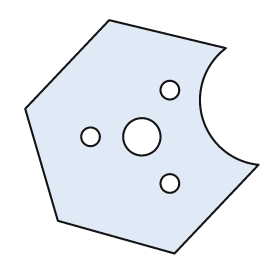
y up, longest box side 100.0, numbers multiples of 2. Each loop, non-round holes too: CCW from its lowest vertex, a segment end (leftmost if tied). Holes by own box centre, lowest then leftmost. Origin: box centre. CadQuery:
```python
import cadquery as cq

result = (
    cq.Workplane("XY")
    .moveTo(14.0, -50.0)
    .lineTo(50.0, -12.0)
    .threePointArc((26.0, 8.0), (36.0, 38.0))
    .lineTo(-14.0, 50.0)
    .lineTo(-50.0, 12.0)
    .lineTo(-36.0, -36.0)
    .close()
    .moveTo(12.0, -20.0)
    .circle(4.0)
    .moveTo(-22.0, 0.0)
    .circle(4.0)
    .moveTo(0.0, 0.0)
    .circle(8.0)
    .moveTo(12.0, 20.0)
    .circle(4.0)
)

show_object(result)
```